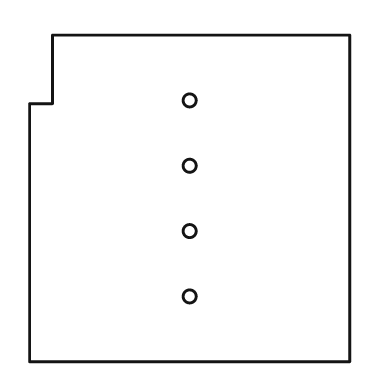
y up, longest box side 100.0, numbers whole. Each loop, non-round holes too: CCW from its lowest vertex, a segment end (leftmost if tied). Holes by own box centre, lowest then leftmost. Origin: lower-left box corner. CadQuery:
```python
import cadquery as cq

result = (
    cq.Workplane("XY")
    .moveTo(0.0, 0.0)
    .lineTo(98.0, 0.0)
    .lineTo(98.0, 100.0)
    .lineTo(7.0, 100.0)
    .lineTo(7.0, 79.0)
    .lineTo(0.0, 79.0)
    .close()
    .moveTo(49.0, 20.0)
    .circle(2.0)
    .moveTo(49.0, 40.0)
    .circle(2.0)
    .moveTo(49.0, 60.0)
    .circle(2.0)
    .moveTo(49.0, 80.0)
    .circle(2.0)
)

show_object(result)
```